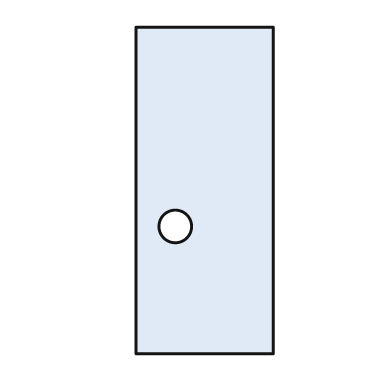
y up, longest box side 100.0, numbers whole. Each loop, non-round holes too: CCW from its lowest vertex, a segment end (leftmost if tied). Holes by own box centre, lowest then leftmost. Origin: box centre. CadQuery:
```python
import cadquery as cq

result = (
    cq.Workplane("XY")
    .moveTo(-21.0, -50.0)
    .lineTo(21.0, -50.0)
    .lineTo(21.0, 50.0)
    .lineTo(-21.0, 50.0)
    .close()
    .moveTo(-9.0, -11.0)
    .circle(5.0)
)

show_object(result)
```